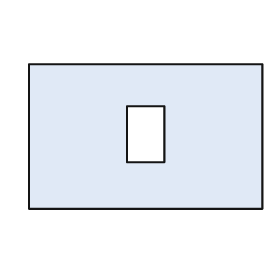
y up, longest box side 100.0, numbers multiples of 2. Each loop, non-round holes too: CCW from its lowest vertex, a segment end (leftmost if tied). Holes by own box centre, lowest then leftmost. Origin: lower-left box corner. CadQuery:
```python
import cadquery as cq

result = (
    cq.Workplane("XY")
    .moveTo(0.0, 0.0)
    .lineTo(100.0, 0.0)
    .lineTo(100.0, 62.0)
    .lineTo(0.0, 62.0)
    .close()
    .moveTo(42.0, 20.0)
    .lineTo(58.0, 20.0)
    .lineTo(58.0, 44.0)
    .lineTo(42.0, 44.0)
    .close()
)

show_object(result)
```